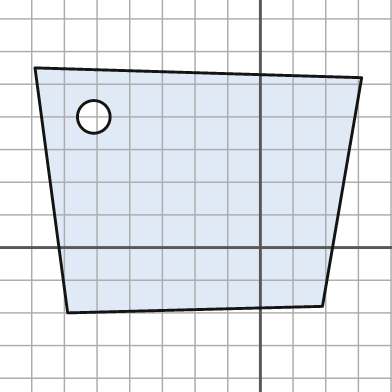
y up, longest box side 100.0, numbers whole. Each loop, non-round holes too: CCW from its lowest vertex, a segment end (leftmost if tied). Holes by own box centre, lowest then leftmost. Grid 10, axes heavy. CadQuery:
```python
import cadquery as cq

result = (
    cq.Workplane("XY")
    .moveTo(-59.0, -20.0)
    .lineTo(19.0, -18.0)
    .lineTo(31.0, 52.0)
    .lineTo(-69.0, 55.0)
    .close()
    .moveTo(-51.0, 40.0)
    .circle(5.0)
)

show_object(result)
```